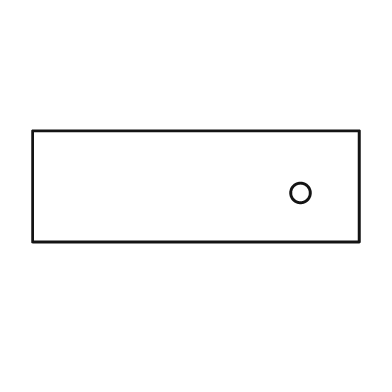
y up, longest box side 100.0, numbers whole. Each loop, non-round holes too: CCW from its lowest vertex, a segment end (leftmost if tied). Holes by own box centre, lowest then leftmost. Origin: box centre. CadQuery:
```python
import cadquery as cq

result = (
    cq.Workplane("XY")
    .moveTo(-50.0, -17.0)
    .lineTo(50.0, -17.0)
    .lineTo(50.0, 17.0)
    .lineTo(-50.0, 17.0)
    .close()
    .moveTo(32.0, -2.0)
    .circle(3.0)
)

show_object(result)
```